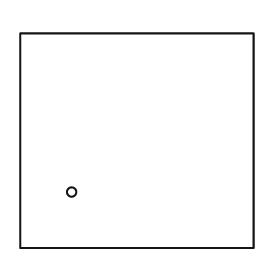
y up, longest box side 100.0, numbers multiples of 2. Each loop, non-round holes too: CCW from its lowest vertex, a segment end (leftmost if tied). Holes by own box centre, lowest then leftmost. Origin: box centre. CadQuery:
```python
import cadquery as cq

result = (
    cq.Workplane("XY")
    .moveTo(-50.0, -46.0)
    .lineTo(50.0, -46.0)
    .lineTo(50.0, 46.0)
    .lineTo(-50.0, 46.0)
    .close()
    .moveTo(-28.0, -22.0)
    .circle(2.0)
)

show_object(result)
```